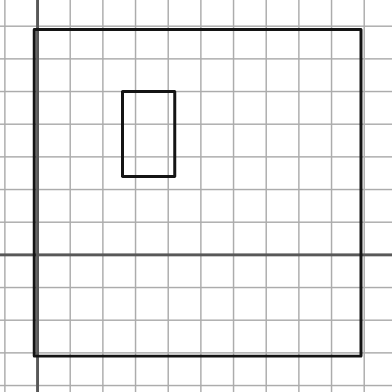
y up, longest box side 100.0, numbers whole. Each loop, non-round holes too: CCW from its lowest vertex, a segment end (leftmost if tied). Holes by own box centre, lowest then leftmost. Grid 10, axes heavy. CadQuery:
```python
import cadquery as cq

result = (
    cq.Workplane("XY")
    .moveTo(-1.0, -31.0)
    .lineTo(99.0, -31.0)
    .lineTo(99.0, 69.0)
    .lineTo(-1.0, 69.0)
    .close()
    .moveTo(26.0, 24.0)
    .lineTo(42.0, 24.0)
    .lineTo(42.0, 50.0)
    .lineTo(26.0, 50.0)
    .close()
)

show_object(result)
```